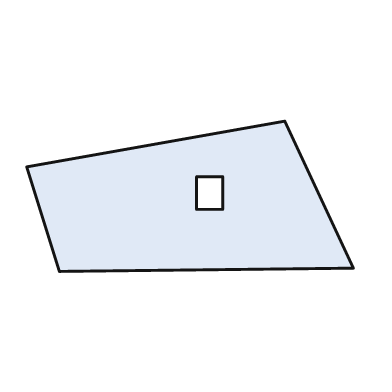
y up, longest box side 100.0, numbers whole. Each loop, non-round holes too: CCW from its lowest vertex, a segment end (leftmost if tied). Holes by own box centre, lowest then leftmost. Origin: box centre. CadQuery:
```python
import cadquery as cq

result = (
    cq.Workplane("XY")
    .moveTo(-40.0, -23.0)
    .lineTo(50.0, -22.0)
    .lineTo(29.0, 23.0)
    .lineTo(-50.0, 9.0)
    .close()
    .moveTo(2.0, -4.0)
    .lineTo(10.0, -4.0)
    .lineTo(10.0, 6.0)
    .lineTo(2.0, 6.0)
    .close()
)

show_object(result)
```